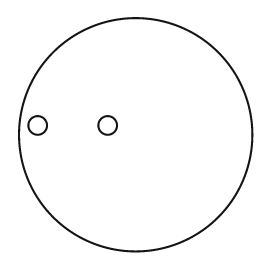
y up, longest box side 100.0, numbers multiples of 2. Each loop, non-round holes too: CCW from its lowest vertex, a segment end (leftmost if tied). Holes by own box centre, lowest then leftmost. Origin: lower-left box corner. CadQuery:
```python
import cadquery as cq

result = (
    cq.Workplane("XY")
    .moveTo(50.0, 50.0)
    .circle(50.0)
    .moveTo(8.0, 54.0)
    .circle(4.0)
    .moveTo(38.0, 54.0)
    .circle(4.0)
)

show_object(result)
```